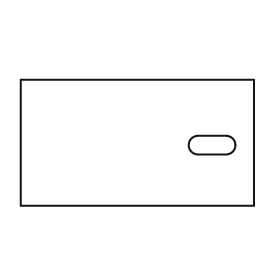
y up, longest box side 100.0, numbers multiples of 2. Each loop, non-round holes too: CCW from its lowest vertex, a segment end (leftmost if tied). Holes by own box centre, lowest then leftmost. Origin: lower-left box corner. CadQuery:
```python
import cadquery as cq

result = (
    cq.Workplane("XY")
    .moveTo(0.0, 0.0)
    .lineTo(100.0, 0.0)
    .lineTo(100.0, 54.0)
    .lineTo(0.0, 54.0)
    .close()
    .moveTo(76.0, 22.0)
    .lineTo(88.0, 22.0)
    .threePointArc((92.0, 26.0), (88.0, 30.0))
    .lineTo(76.0, 30.0)
    .threePointArc((72.0, 26.0), (76.0, 22.0))
    .close()
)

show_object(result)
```